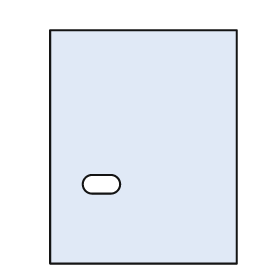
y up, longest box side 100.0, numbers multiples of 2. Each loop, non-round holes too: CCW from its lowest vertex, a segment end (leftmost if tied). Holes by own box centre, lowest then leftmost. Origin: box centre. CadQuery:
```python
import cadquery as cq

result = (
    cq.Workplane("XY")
    .moveTo(-40.0, -50.0)
    .lineTo(40.0, -50.0)
    .lineTo(40.0, 50.0)
    .lineTo(-40.0, 50.0)
    .close()
    .moveTo(-22.0, -20.0)
    .lineTo(-14.0, -20.0)
    .threePointArc((-10.0, -16.0), (-14.0, -12.0))
    .lineTo(-22.0, -12.0)
    .threePointArc((-26.0, -16.0), (-22.0, -20.0))
    .close()
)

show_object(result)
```